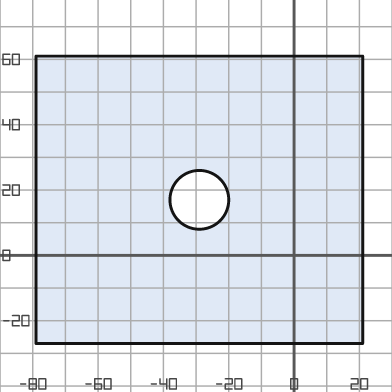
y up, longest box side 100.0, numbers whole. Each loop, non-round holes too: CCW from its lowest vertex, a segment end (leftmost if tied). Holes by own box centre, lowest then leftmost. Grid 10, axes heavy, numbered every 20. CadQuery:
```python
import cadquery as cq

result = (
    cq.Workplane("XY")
    .moveTo(-79.0, -27.0)
    .lineTo(21.0, -27.0)
    .lineTo(21.0, 61.0)
    .lineTo(-79.0, 61.0)
    .close()
    .moveTo(-29.0, 17.0)
    .circle(9.0)
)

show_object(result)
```